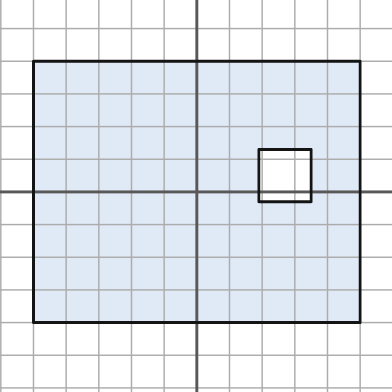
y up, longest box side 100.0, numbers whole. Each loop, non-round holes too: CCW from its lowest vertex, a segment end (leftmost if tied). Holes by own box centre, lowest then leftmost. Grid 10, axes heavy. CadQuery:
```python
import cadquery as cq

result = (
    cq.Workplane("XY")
    .moveTo(-50.0, -40.0)
    .lineTo(50.0, -40.0)
    .lineTo(50.0, 40.0)
    .lineTo(-50.0, 40.0)
    .close()
    .moveTo(19.0, -3.0)
    .lineTo(35.0, -3.0)
    .lineTo(35.0, 13.0)
    .lineTo(19.0, 13.0)
    .close()
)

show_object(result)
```